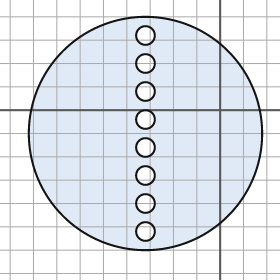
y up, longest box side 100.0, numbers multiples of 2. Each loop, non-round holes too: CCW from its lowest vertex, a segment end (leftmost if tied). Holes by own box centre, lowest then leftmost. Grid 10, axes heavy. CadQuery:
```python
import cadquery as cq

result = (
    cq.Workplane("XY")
    .moveTo(-32.0, -10.0)
    .circle(50.0)
    .moveTo(-32.0, -52.0)
    .circle(4.0)
    .moveTo(-32.0, -40.0)
    .circle(4.0)
    .moveTo(-32.0, -28.0)
    .circle(4.0)
    .moveTo(-32.0, -16.0)
    .circle(4.0)
    .moveTo(-32.0, -4.0)
    .circle(4.0)
    .moveTo(-32.0, 8.0)
    .circle(4.0)
    .moveTo(-32.0, 20.0)
    .circle(4.0)
    .moveTo(-32.0, 32.0)
    .circle(4.0)
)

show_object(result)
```